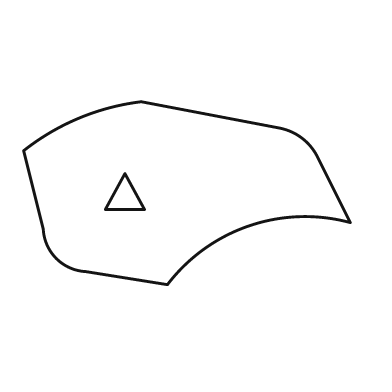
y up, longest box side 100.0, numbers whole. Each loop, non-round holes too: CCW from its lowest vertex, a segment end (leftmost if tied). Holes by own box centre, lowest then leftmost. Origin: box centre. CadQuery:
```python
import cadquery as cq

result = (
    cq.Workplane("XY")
    .moveTo(-6.0, -28.0)
    .threePointArc((19.0, -10.0), (50.0, -9.0))
    .lineTo(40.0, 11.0)
    .threePointArc((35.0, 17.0), (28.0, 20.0))
    .lineTo(-14.0, 28.0)
    .threePointArc((-33.0, 23.0), (-50.0, 13.0))
    .lineTo(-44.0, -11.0)
    .threePointArc((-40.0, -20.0), (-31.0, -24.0))
    .close()
    .moveTo(-25.0, -5.0)
    .lineTo(-13.0, -5.0)
    .lineTo(-19.0, 6.0)
    .close()
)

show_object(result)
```